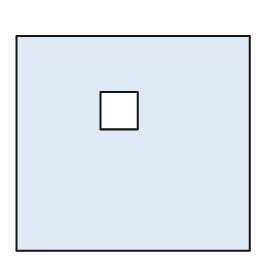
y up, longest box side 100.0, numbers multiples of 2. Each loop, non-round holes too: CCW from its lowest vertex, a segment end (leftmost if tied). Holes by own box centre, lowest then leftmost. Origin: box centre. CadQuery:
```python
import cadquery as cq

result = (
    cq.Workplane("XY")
    .moveTo(-50.0, -46.0)
    .lineTo(50.0, -46.0)
    .lineTo(50.0, 46.0)
    .lineTo(-50.0, 46.0)
    .close()
    .moveTo(-14.0, 6.0)
    .lineTo(2.0, 6.0)
    .lineTo(2.0, 22.0)
    .lineTo(-14.0, 22.0)
    .close()
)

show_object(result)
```